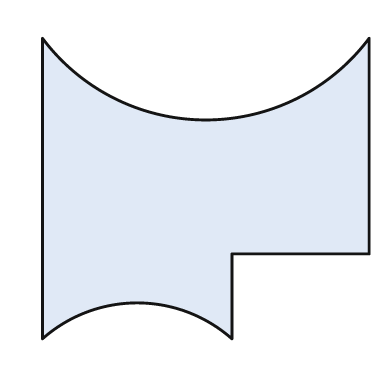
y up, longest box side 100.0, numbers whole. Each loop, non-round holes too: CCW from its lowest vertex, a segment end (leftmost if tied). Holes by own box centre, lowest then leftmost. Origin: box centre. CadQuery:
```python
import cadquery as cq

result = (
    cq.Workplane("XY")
    .moveTo(-50.0, -46.0)
    .threePointArc((-21.0, -35.0), (8.0, -46.0))
    .lineTo(8.0, -20.0)
    .lineTo(50.0, -20.0)
    .lineTo(50.0, 46.0)
    .threePointArc((0.0, 21.0), (-50.0, 46.0))
    .close()
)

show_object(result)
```